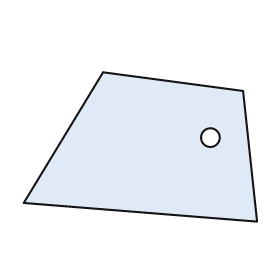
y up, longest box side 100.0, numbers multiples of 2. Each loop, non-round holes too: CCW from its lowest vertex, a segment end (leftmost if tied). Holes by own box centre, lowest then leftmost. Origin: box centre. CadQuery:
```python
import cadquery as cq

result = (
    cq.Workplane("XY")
    .moveTo(50.0, -32.0)
    .lineTo(44.0, 24.0)
    .lineTo(-16.0, 32.0)
    .lineTo(-50.0, -24.0)
    .close()
    .moveTo(30.0, 4.0)
    .circle(4.0)
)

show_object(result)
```